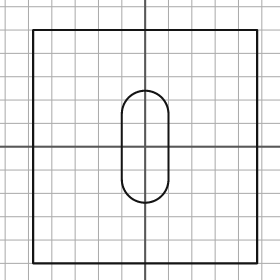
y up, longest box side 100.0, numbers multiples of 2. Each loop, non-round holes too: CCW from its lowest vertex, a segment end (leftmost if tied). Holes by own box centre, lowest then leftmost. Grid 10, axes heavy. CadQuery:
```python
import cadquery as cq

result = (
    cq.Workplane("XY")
    .moveTo(-48.0, -50.0)
    .lineTo(48.0, -50.0)
    .lineTo(48.0, 50.0)
    .lineTo(-48.0, 50.0)
    .close()
    .moveTo(-10.0, -14.0)
    .threePointArc((0.0, -24.0), (10.0, -14.0))
    .lineTo(10.0, 14.0)
    .threePointArc((0.0, 24.0), (-10.0, 14.0))
    .close()
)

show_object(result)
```